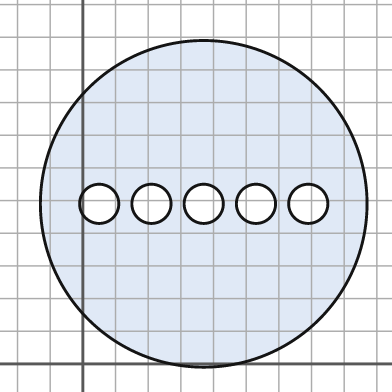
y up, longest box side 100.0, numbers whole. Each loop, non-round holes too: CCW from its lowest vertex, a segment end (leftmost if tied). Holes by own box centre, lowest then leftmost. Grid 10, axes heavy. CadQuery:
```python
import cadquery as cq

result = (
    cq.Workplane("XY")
    .moveTo(37.0, 49.0)
    .circle(50.0)
    .moveTo(5.0, 49.0)
    .circle(6.0)
    .moveTo(21.0, 49.0)
    .circle(6.0)
    .moveTo(37.0, 49.0)
    .circle(6.0)
    .moveTo(53.0, 49.0)
    .circle(6.0)
    .moveTo(69.0, 49.0)
    .circle(6.0)
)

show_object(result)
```